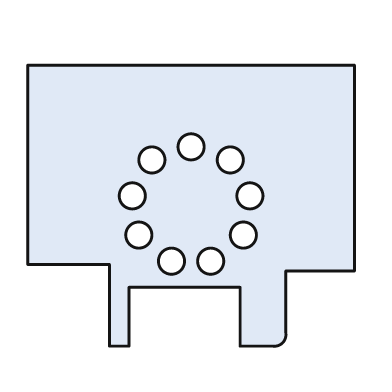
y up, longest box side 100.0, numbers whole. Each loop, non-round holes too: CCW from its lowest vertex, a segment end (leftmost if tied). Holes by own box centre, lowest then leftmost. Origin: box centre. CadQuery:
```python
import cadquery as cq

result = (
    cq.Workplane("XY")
    .moveTo(-25.0, -43.0)
    .lineTo(-19.0, -43.0)
    .lineTo(-19.0, -25.0)
    .lineTo(15.0, -25.0)
    .lineTo(15.0, -43.0)
    .lineTo(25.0, -43.0)
    .threePointArc((28.0, -42.0), (29.0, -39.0))
    .lineTo(29.0, -20.0)
    .lineTo(50.0, -20.0)
    .lineTo(50.0, 43.0)
    .lineTo(-50.0, 43.0)
    .lineTo(-50.0, -18.0)
    .lineTo(-25.0, -18.0)
    .close()
    .moveTo(-6.0, -17.0)
    .circle(4.0)
    .moveTo(6.0, -17.0)
    .circle(4.0)
    .moveTo(-16.0, -9.0)
    .circle(4.0)
    .moveTo(16.0, -9.0)
    .circle(4.0)
    .moveTo(-18.0, 3.0)
    .circle(4.0)
    .moveTo(18.0, 3.0)
    .circle(4.0)
    .moveTo(-12.0, 14.0)
    .circle(4.0)
    .moveTo(12.0, 14.0)
    .circle(4.0)
    .moveTo(0.0, 18.0)
    .circle(4.0)
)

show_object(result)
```